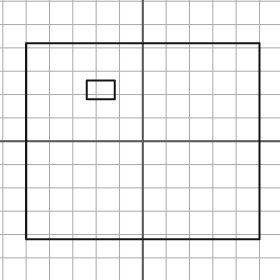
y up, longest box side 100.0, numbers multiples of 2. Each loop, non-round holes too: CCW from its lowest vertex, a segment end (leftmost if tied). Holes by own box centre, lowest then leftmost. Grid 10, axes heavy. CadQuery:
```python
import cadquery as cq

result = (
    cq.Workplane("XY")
    .moveTo(-50.0, -42.0)
    .lineTo(50.0, -42.0)
    .lineTo(50.0, 42.0)
    .lineTo(-50.0, 42.0)
    .close()
    .moveTo(-24.0, 18.0)
    .lineTo(-12.0, 18.0)
    .lineTo(-12.0, 26.0)
    .lineTo(-24.0, 26.0)
    .close()
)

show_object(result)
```